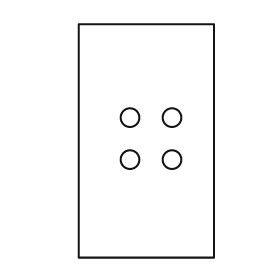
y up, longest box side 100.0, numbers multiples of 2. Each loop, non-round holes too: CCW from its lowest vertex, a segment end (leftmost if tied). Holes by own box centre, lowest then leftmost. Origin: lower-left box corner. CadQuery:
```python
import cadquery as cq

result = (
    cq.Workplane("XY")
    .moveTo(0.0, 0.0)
    .lineTo(58.0, 0.0)
    .lineTo(58.0, 100.0)
    .lineTo(0.0, 100.0)
    .close()
    .moveTo(22.0, 42.0)
    .circle(4.0)
    .moveTo(40.0, 42.0)
    .circle(4.0)
    .moveTo(22.0, 60.0)
    .circle(4.0)
    .moveTo(40.0, 60.0)
    .circle(4.0)
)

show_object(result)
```